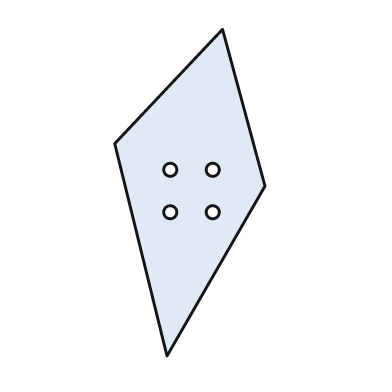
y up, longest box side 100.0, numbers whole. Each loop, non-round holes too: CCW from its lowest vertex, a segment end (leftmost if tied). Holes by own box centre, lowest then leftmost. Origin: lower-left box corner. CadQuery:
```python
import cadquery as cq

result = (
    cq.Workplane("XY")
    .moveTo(16.0, 0.0)
    .lineTo(46.0, 52.0)
    .lineTo(33.0, 100.0)
    .lineTo(0.0, 65.0)
    .close()
    .moveTo(17.0, 44.0)
    .circle(2.0)
    .moveTo(30.0, 44.0)
    .circle(2.0)
    .moveTo(17.0, 57.0)
    .circle(2.0)
    .moveTo(30.0, 57.0)
    .circle(2.0)
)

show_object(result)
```